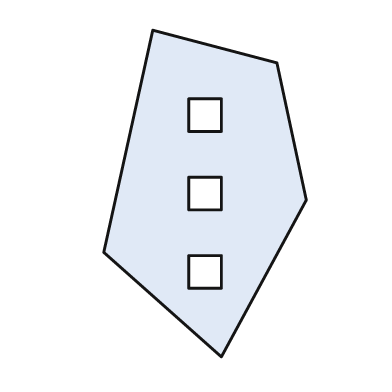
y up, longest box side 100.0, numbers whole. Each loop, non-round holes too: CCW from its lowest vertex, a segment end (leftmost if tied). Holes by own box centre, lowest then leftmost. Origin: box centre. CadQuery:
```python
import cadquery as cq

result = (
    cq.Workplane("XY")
    .moveTo(5.0, -50.0)
    .lineTo(31.0, -2.0)
    .lineTo(22.0, 40.0)
    .lineTo(-16.0, 50.0)
    .lineTo(-31.0, -18.0)
    .close()
    .moveTo(-5.0, -29.0)
    .lineTo(5.0, -29.0)
    .lineTo(5.0, -19.0)
    .lineTo(-5.0, -19.0)
    .close()
    .moveTo(-5.0, -5.0)
    .lineTo(5.0, -5.0)
    .lineTo(5.0, 5.0)
    .lineTo(-5.0, 5.0)
    .close()
    .moveTo(-5.0, 19.0)
    .lineTo(5.0, 19.0)
    .lineTo(5.0, 29.0)
    .lineTo(-5.0, 29.0)
    .close()
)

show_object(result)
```